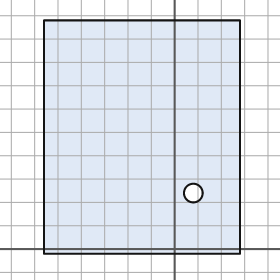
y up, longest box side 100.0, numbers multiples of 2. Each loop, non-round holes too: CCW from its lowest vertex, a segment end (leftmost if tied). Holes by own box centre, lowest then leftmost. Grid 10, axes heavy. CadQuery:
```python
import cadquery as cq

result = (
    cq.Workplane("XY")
    .moveTo(-56.0, -2.0)
    .lineTo(28.0, -2.0)
    .lineTo(28.0, 98.0)
    .lineTo(-56.0, 98.0)
    .close()
    .moveTo(8.0, 24.0)
    .circle(4.0)
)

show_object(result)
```